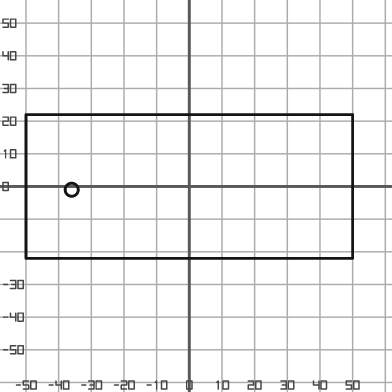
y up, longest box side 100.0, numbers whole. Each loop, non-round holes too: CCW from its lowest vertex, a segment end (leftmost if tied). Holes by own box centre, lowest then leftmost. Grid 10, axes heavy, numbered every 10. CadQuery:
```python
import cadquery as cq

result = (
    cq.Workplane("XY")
    .moveTo(-50.0, -22.0)
    .lineTo(50.0, -22.0)
    .lineTo(50.0, 22.0)
    .lineTo(-50.0, 22.0)
    .close()
    .moveTo(-36.0, -1.0)
    .circle(2.0)
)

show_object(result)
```